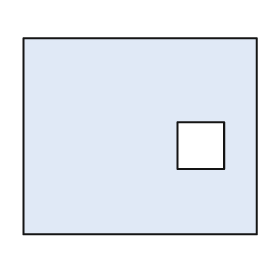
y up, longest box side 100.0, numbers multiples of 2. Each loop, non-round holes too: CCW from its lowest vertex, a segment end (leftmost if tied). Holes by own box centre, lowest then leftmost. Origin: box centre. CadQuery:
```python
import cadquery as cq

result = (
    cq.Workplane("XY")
    .moveTo(-50.0, -42.0)
    .lineTo(50.0, -42.0)
    .lineTo(50.0, 42.0)
    .lineTo(-50.0, 42.0)
    .close()
    .moveTo(16.0, -14.0)
    .lineTo(36.0, -14.0)
    .lineTo(36.0, 6.0)
    .lineTo(16.0, 6.0)
    .close()
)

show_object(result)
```